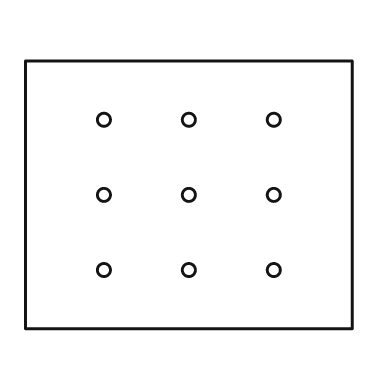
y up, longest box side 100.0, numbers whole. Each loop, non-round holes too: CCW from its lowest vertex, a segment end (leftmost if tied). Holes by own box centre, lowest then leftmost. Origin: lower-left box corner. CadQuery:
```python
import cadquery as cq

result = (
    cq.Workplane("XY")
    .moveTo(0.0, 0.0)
    .lineTo(100.0, 0.0)
    .lineTo(100.0, 82.0)
    .lineTo(0.0, 82.0)
    .close()
    .moveTo(24.0, 18.0)
    .circle(2.0)
    .moveTo(50.0, 18.0)
    .circle(2.0)
    .moveTo(76.0, 18.0)
    .circle(2.0)
    .moveTo(24.0, 41.0)
    .circle(2.0)
    .moveTo(50.0, 41.0)
    .circle(2.0)
    .moveTo(76.0, 41.0)
    .circle(2.0)
    .moveTo(24.0, 64.0)
    .circle(2.0)
    .moveTo(50.0, 64.0)
    .circle(2.0)
    .moveTo(76.0, 64.0)
    .circle(2.0)
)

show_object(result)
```